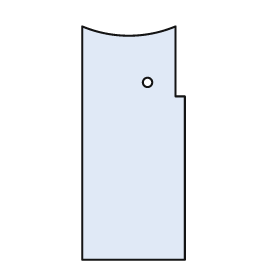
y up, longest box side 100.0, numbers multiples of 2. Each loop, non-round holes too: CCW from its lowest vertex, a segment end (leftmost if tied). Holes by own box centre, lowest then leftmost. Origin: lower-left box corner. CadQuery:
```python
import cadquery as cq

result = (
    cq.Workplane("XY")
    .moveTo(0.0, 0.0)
    .lineTo(44.0, 0.0)
    .lineTo(44.0, 70.0)
    .lineTo(40.0, 70.0)
    .lineTo(40.0, 100.0)
    .threePointArc((20.0, 96.0), (0.0, 100.0))
    .close()
    .moveTo(28.0, 76.0)
    .circle(2.0)
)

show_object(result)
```